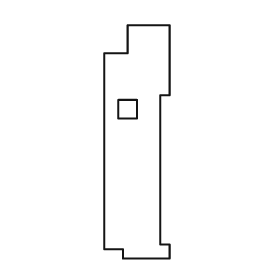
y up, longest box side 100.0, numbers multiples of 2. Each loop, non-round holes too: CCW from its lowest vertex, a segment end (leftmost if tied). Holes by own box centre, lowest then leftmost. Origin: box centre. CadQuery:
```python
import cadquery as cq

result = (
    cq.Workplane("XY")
    .moveTo(-6.0, -50.0)
    .lineTo(14.0, -50.0)
    .lineTo(14.0, -44.0)
    .lineTo(10.0, -44.0)
    .lineTo(10.0, 20.0)
    .lineTo(14.0, 20.0)
    .lineTo(14.0, 50.0)
    .lineTo(-4.0, 50.0)
    .lineTo(-4.0, 38.0)
    .lineTo(-14.0, 38.0)
    .lineTo(-14.0, -46.0)
    .lineTo(-6.0, -46.0)
    .close()
    .moveTo(-8.0, 10.0)
    .lineTo(0.0, 10.0)
    .lineTo(0.0, 18.0)
    .lineTo(-8.0, 18.0)
    .close()
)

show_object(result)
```